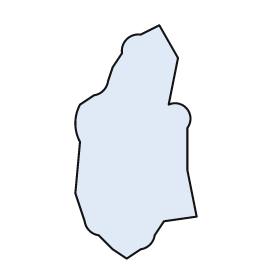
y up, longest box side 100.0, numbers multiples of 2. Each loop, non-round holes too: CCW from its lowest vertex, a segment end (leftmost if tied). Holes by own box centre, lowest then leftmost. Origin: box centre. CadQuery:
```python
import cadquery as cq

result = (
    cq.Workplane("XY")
    .moveTo(-4.0, -50.0)
    .lineTo(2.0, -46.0)
    .threePointArc((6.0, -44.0), (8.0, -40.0))
    .lineTo(12.0, -34.0)
    .lineTo(26.0, -32.0)
    .lineTo(22.0, -12.0)
    .lineTo(22.0, 6.0)
    .threePointArc((22.0, 14.0), (14.0, 16.0))
    .lineTo(18.0, 36.0)
    .lineTo(10.0, 50.0)
    .lineTo(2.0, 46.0)
    .threePointArc((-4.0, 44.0), (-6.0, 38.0))
    .lineTo(-10.0, 32.0)
    .lineTo(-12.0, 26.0)
    .threePointArc((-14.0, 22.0), (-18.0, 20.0))
    .lineTo(-24.0, 16.0)
    .threePointArc((-26.0, 8.0), (-24.0, 0.0))
    .lineTo(-26.0, -22.0)
    .lineTo(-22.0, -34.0)
    .threePointArc((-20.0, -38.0), (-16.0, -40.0))
    .lineTo(-10.0, -46.0)
    .close()
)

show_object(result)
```